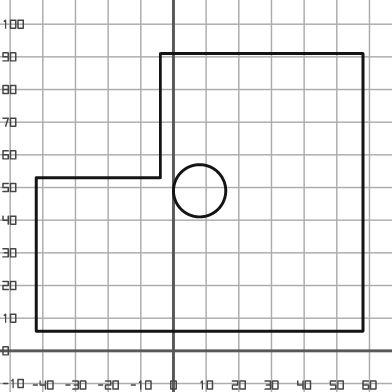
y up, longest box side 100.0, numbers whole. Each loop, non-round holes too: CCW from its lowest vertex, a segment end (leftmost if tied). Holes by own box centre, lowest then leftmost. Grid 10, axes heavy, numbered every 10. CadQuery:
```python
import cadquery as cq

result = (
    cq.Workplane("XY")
    .moveTo(-42.0, 6.0)
    .lineTo(58.0, 6.0)
    .lineTo(58.0, 91.0)
    .lineTo(-4.0, 91.0)
    .lineTo(-4.0, 53.0)
    .lineTo(-42.0, 53.0)
    .close()
    .moveTo(8.0, 49.0)
    .circle(8.0)
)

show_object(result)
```